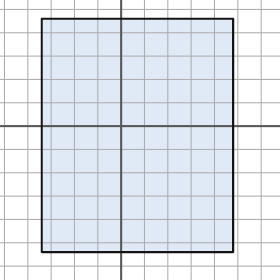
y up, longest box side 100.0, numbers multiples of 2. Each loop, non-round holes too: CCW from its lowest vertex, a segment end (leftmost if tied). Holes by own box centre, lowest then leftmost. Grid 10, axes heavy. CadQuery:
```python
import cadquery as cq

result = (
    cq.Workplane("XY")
    .moveTo(-34.0, -54.0)
    .lineTo(48.0, -54.0)
    .lineTo(48.0, 46.0)
    .lineTo(-34.0, 46.0)
    .close()
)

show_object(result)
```